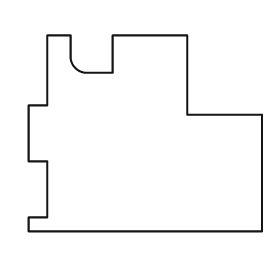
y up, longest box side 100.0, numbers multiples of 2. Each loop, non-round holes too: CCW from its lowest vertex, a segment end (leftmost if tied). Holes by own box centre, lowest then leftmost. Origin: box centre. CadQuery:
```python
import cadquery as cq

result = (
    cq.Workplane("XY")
    .moveTo(-50.0, -42.0)
    .lineTo(50.0, -42.0)
    .lineTo(50.0, 8.0)
    .lineTo(18.0, 8.0)
    .lineTo(18.0, 42.0)
    .lineTo(-14.0, 42.0)
    .lineTo(-14.0, 26.0)
    .lineTo(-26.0, 26.0)
    .threePointArc((-30.0, 28.0), (-32.0, 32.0))
    .lineTo(-32.0, 42.0)
    .lineTo(-42.0, 42.0)
    .lineTo(-42.0, 12.0)
    .lineTo(-50.0, 12.0)
    .lineTo(-50.0, -12.0)
    .lineTo(-42.0, -12.0)
    .lineTo(-42.0, -36.0)
    .lineTo(-50.0, -36.0)
    .close()
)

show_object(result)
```